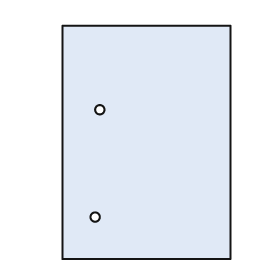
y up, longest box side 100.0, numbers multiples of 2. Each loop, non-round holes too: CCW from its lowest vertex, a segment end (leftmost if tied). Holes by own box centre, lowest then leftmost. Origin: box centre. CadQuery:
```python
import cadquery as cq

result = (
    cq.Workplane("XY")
    .moveTo(-36.0, -50.0)
    .lineTo(36.0, -50.0)
    .lineTo(36.0, 50.0)
    .lineTo(-36.0, 50.0)
    .close()
    .moveTo(-22.0, -32.0)
    .circle(2.0)
    .moveTo(-20.0, 14.0)
    .circle(2.0)
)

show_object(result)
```